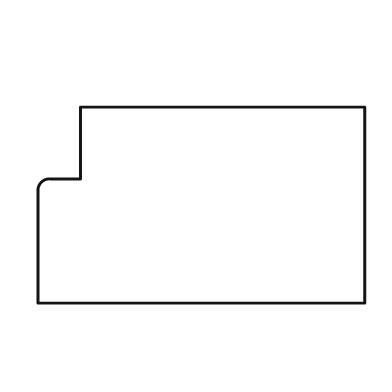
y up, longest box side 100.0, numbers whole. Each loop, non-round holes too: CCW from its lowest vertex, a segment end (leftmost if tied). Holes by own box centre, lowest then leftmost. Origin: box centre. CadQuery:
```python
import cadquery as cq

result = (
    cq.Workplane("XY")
    .moveTo(-50.0, -30.0)
    .lineTo(50.0, -30.0)
    .lineTo(50.0, 30.0)
    .lineTo(-37.0, 30.0)
    .lineTo(-37.0, 8.0)
    .lineTo(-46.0, 8.0)
    .threePointArc((-49.0, 7.0), (-50.0, 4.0))
    .close()
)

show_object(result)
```